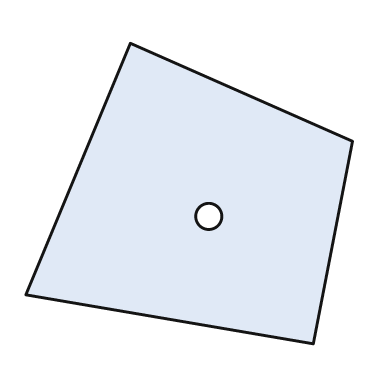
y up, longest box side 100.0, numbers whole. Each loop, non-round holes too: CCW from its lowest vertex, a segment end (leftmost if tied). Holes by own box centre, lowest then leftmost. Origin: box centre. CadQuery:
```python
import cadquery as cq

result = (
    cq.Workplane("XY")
    .moveTo(38.0, -46.0)
    .lineTo(50.0, 16.0)
    .lineTo(-18.0, 46.0)
    .lineTo(-50.0, -31.0)
    .close()
    .moveTo(6.0, -7.0)
    .circle(4.0)
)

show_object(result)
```